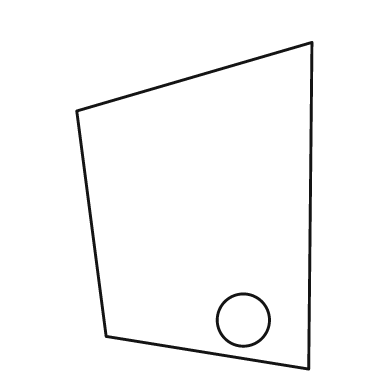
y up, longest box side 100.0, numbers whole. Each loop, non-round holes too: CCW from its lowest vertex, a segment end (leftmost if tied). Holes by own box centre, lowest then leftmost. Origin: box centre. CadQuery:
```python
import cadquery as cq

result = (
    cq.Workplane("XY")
    .moveTo(35.0, -50.0)
    .lineTo(36.0, 50.0)
    .lineTo(-36.0, 29.0)
    .lineTo(-27.0, -40.0)
    .close()
    .moveTo(15.0, -35.0)
    .circle(8.0)
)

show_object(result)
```